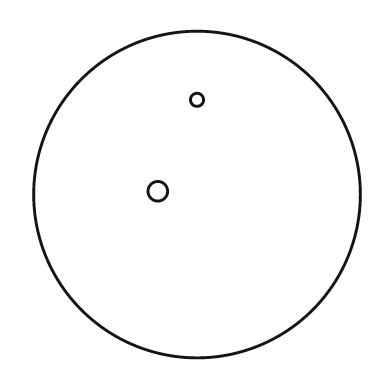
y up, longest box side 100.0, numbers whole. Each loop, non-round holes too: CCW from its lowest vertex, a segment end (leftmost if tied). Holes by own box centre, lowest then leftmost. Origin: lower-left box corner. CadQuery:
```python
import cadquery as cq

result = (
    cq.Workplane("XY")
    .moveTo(50.0, 50.0)
    .circle(50.0)
    .moveTo(38.0, 51.0)
    .circle(3.0)
    .moveTo(50.0, 79.0)
    .circle(2.0)
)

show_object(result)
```